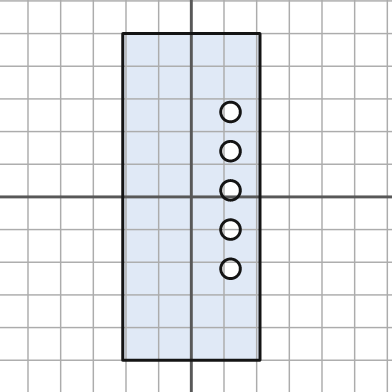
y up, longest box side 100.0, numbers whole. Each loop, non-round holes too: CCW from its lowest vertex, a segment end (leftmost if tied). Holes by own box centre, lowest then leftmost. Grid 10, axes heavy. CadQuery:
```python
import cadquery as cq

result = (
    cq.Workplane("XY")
    .moveTo(-21.0, -50.0)
    .lineTo(21.0, -50.0)
    .lineTo(21.0, 50.0)
    .lineTo(-21.0, 50.0)
    .close()
    .moveTo(12.0, -22.0)
    .circle(3.0)
    .moveTo(12.0, -10.0)
    .circle(3.0)
    .moveTo(12.0, 2.0)
    .circle(3.0)
    .moveTo(12.0, 14.0)
    .circle(3.0)
    .moveTo(12.0, 26.0)
    .circle(3.0)
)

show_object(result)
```